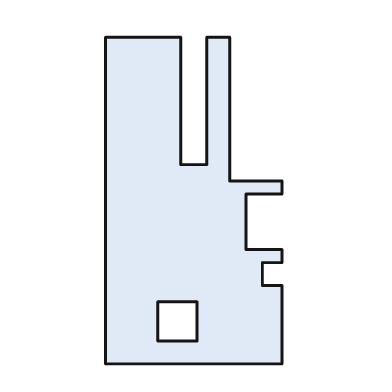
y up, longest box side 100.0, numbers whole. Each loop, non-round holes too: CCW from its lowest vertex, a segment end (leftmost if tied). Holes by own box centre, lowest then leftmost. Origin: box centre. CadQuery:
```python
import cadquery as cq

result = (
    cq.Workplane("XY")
    .moveTo(-27.0, -50.0)
    .lineTo(27.0, -50.0)
    .lineTo(27.0, -26.0)
    .lineTo(21.0, -26.0)
    .lineTo(21.0, -19.0)
    .lineTo(27.0, -19.0)
    .lineTo(27.0, -15.0)
    .lineTo(16.0, -15.0)
    .lineTo(16.0, 2.0)
    .lineTo(27.0, 2.0)
    .lineTo(27.0, 6.0)
    .lineTo(11.0, 6.0)
    .lineTo(11.0, 50.0)
    .lineTo(4.0, 50.0)
    .lineTo(4.0, 11.0)
    .lineTo(-4.0, 11.0)
    .lineTo(-4.0, 50.0)
    .lineTo(-27.0, 50.0)
    .close()
    .moveTo(-11.0, -43.0)
    .lineTo(1.0, -43.0)
    .lineTo(1.0, -31.0)
    .lineTo(-11.0, -31.0)
    .close()
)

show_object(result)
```